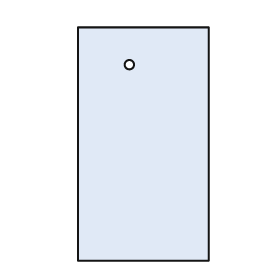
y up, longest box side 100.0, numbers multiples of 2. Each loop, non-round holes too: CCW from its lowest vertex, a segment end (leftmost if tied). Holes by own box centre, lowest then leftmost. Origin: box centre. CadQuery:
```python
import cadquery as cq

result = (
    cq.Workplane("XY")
    .moveTo(-28.0, -50.0)
    .lineTo(28.0, -50.0)
    .lineTo(28.0, 50.0)
    .lineTo(-28.0, 50.0)
    .close()
    .moveTo(-6.0, 34.0)
    .circle(2.0)
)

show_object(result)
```